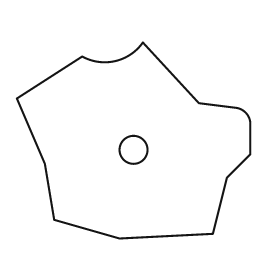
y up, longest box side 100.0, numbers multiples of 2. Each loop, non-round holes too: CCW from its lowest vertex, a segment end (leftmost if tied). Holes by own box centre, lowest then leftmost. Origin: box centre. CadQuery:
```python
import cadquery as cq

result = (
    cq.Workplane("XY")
    .moveTo(-6.0, -42.0)
    .lineTo(34.0, -40.0)
    .lineTo(40.0, -16.0)
    .lineTo(50.0, -6.0)
    .lineTo(50.0, 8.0)
    .threePointArc((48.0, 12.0), (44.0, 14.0))
    .lineTo(28.0, 16.0)
    .lineTo(4.0, 42.0)
    .threePointArc((-8.0, 34.0), (-22.0, 36.0))
    .lineTo(-50.0, 18.0)
    .lineTo(-38.0, -10.0)
    .lineTo(-34.0, -34.0)
    .close()
    .moveTo(0.0, -4.0)
    .circle(6.0)
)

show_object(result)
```